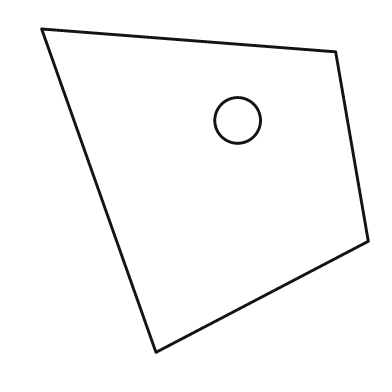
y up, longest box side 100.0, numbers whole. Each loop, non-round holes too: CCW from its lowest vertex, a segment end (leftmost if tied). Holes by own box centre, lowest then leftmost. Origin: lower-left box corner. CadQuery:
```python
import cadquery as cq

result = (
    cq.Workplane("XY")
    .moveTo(35.0, 0.0)
    .lineTo(100.0, 34.0)
    .lineTo(90.0, 92.0)
    .lineTo(0.0, 99.0)
    .close()
    .moveTo(60.0, 71.0)
    .circle(7.0)
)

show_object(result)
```